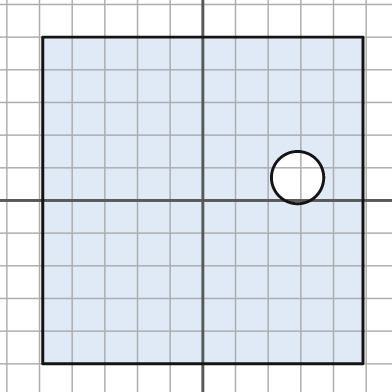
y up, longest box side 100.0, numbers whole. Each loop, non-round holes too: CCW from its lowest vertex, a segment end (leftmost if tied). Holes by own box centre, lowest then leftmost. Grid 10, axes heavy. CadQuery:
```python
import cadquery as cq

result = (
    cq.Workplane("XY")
    .moveTo(-49.0, -50.0)
    .lineTo(49.0, -50.0)
    .lineTo(49.0, 50.0)
    .lineTo(-49.0, 50.0)
    .close()
    .moveTo(29.0, 7.0)
    .circle(8.0)
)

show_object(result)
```